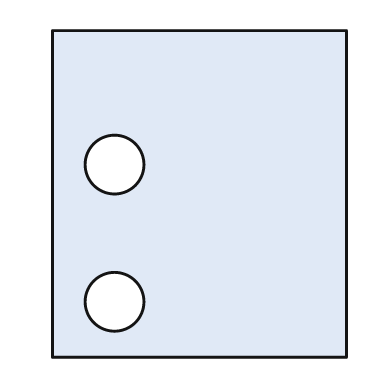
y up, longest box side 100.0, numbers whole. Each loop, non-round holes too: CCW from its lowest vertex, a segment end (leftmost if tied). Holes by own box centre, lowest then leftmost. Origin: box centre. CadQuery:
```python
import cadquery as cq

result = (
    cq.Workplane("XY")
    .moveTo(-45.0, -50.0)
    .lineTo(45.0, -50.0)
    .lineTo(45.0, 50.0)
    .lineTo(-45.0, 50.0)
    .close()
    .moveTo(-26.0, -33.0)
    .circle(9.0)
    .moveTo(-26.0, 9.0)
    .circle(9.0)
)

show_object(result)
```